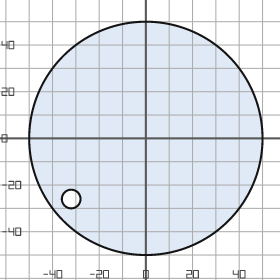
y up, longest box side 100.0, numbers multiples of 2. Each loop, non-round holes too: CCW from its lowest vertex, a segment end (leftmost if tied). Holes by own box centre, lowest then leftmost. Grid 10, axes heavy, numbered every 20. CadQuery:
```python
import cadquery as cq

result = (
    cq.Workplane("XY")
    .moveTo(0.0, 0.0)
    .circle(50.0)
    .moveTo(-32.0, -26.0)
    .circle(4.0)
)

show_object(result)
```